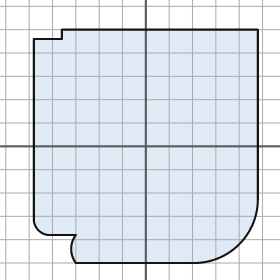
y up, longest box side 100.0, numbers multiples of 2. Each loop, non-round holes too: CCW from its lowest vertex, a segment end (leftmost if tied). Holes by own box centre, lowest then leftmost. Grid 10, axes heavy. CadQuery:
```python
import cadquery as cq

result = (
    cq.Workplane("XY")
    .moveTo(-30.0, -50.0)
    .lineTo(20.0, -50.0)
    .threePointArc((40.0, -42.0), (48.0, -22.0))
    .lineTo(48.0, 50.0)
    .lineTo(-36.0, 50.0)
    .lineTo(-36.0, 46.0)
    .lineTo(-48.0, 46.0)
    .lineTo(-48.0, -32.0)
    .threePointArc((-46.0, -36.0), (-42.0, -38.0))
    .lineTo(-30.0, -38.0)
    .threePointArc((-32.0, -44.0), (-30.0, -50.0))
    .close()
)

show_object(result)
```